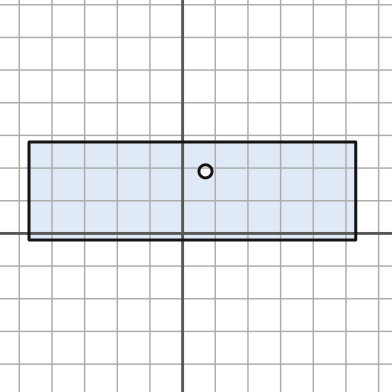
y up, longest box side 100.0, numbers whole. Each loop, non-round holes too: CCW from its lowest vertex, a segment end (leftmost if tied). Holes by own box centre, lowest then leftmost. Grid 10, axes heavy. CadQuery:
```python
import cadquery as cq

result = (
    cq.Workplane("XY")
    .moveTo(-47.0, -2.0)
    .lineTo(53.0, -2.0)
    .lineTo(53.0, 28.0)
    .lineTo(-47.0, 28.0)
    .close()
    .moveTo(7.0, 19.0)
    .circle(2.0)
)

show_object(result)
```